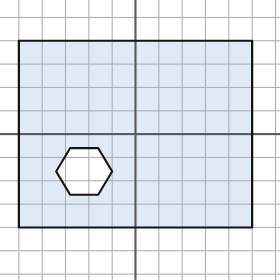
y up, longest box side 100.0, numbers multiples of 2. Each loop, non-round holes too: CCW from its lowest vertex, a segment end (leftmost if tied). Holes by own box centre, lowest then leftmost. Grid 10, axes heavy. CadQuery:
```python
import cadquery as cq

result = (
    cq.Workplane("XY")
    .moveTo(-50.0, -40.0)
    .lineTo(50.0, -40.0)
    .lineTo(50.0, 40.0)
    .lineTo(-50.0, 40.0)
    .close()
    .moveTo(-28.0, -26.0)
    .lineTo(-16.0, -26.0)
    .lineTo(-10.0, -16.0)
    .lineTo(-16.0, -6.0)
    .lineTo(-28.0, -6.0)
    .lineTo(-34.0, -16.0)
    .close()
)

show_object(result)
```